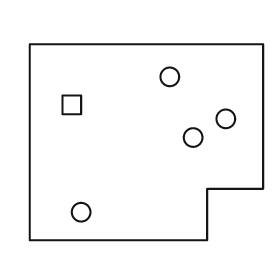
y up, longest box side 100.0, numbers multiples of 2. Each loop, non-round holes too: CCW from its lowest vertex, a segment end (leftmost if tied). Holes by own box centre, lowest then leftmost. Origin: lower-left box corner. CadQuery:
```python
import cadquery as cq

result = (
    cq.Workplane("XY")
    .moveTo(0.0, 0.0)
    .lineTo(76.0, 0.0)
    .lineTo(76.0, 22.0)
    .lineTo(100.0, 22.0)
    .lineTo(100.0, 84.0)
    .lineTo(0.0, 84.0)
    .close()
    .moveTo(22.0, 12.0)
    .circle(4.0)
    .moveTo(70.0, 44.0)
    .circle(4.0)
    .moveTo(84.0, 52.0)
    .circle(4.0)
    .moveTo(14.0, 54.0)
    .lineTo(22.0, 54.0)
    .lineTo(22.0, 62.0)
    .lineTo(14.0, 62.0)
    .close()
    .moveTo(60.0, 70.0)
    .circle(4.0)
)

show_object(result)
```